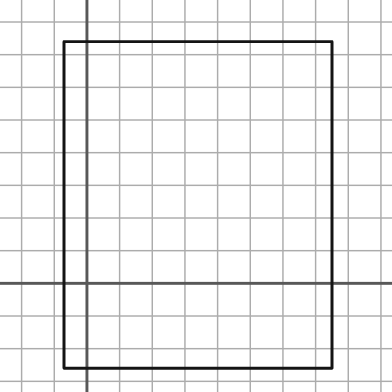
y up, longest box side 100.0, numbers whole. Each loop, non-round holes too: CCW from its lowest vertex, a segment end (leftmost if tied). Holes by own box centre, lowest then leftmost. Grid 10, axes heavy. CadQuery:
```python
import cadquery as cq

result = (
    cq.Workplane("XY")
    .moveTo(-7.0, -26.0)
    .lineTo(75.0, -26.0)
    .lineTo(75.0, 74.0)
    .lineTo(-7.0, 74.0)
    .close()
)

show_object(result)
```